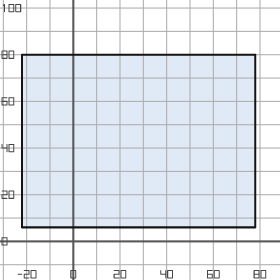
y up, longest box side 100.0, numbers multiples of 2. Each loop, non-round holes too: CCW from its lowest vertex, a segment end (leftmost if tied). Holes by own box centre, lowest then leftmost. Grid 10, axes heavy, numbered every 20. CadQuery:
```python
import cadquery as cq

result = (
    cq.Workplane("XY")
    .moveTo(-22.0, 6.0)
    .lineTo(78.0, 6.0)
    .lineTo(78.0, 80.0)
    .lineTo(-22.0, 80.0)
    .close()
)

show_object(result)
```